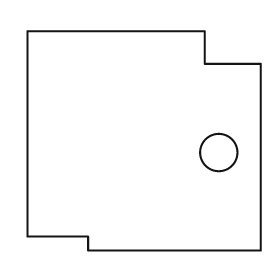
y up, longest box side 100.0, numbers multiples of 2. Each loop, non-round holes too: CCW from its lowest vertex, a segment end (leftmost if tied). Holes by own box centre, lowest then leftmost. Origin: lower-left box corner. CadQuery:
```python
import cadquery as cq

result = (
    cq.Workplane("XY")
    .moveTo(26.0, 0.0)
    .lineTo(100.0, 0.0)
    .lineTo(100.0, 80.0)
    .lineTo(76.0, 80.0)
    .lineTo(76.0, 94.0)
    .lineTo(0.0, 94.0)
    .lineTo(0.0, 6.0)
    .lineTo(26.0, 6.0)
    .close()
    .moveTo(82.0, 42.0)
    .circle(8.0)
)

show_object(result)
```